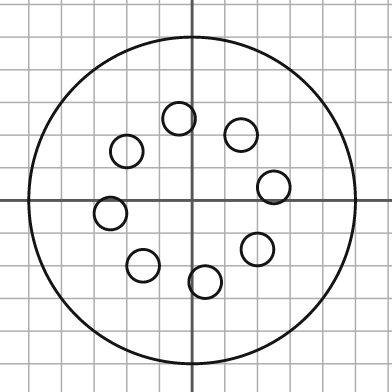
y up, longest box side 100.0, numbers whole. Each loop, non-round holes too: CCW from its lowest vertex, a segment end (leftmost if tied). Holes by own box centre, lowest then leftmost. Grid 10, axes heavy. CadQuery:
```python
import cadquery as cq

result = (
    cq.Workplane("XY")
    .moveTo(0.0, 0.0)
    .circle(50.0)
    .moveTo(4.0, -25.0)
    .circle(5.0)
    .moveTo(-15.0, -20.0)
    .circle(5.0)
    .moveTo(20.0, -15.0)
    .circle(5.0)
    .moveTo(-25.0, -4.0)
    .circle(5.0)
    .moveTo(25.0, 4.0)
    .circle(5.0)
    .moveTo(-20.0, 15.0)
    .circle(5.0)
    .moveTo(15.0, 20.0)
    .circle(5.0)
    .moveTo(-4.0, 25.0)
    .circle(5.0)
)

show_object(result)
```